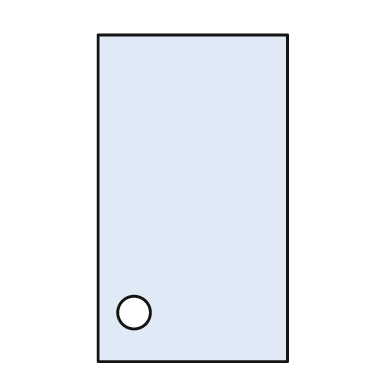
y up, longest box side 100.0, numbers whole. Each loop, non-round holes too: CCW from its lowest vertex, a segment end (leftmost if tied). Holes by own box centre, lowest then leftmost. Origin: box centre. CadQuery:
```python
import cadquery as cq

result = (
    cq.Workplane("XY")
    .moveTo(-29.0, -50.0)
    .lineTo(29.0, -50.0)
    .lineTo(29.0, 50.0)
    .lineTo(-29.0, 50.0)
    .close()
    .moveTo(-18.0, -35.0)
    .circle(5.0)
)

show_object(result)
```